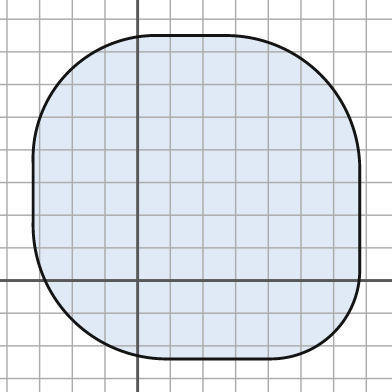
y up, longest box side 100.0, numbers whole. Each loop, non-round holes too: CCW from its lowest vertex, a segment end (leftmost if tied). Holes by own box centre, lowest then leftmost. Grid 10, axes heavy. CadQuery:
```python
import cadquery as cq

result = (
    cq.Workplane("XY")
    .moveTo(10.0, -24.0)
    .lineTo(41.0, -24.0)
    .threePointArc((60.0, -16.0), (68.0, 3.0))
    .lineTo(68.0, 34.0)
    .threePointArc((56.0, 63.0), (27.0, 75.0))
    .lineTo(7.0, 75.0)
    .threePointArc((-21.0, 64.0), (-32.0, 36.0))
    .lineTo(-32.0, 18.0)
    .threePointArc((-20.0, -12.0), (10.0, -24.0))
    .close()
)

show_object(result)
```